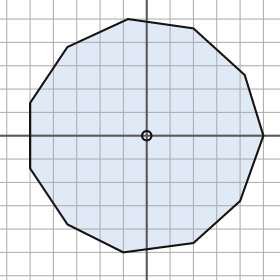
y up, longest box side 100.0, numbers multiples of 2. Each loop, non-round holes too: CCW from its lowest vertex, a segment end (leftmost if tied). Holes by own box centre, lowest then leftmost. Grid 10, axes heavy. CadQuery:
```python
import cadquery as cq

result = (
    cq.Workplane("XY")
    .moveTo(-10.0, -50.0)
    .lineTo(20.0, -46.0)
    .lineTo(40.0, -28.0)
    .lineTo(50.0, 0.0)
    .lineTo(42.0, 26.0)
    .lineTo(20.0, 46.0)
    .lineTo(-8.0, 50.0)
    .lineTo(-34.0, 38.0)
    .lineTo(-50.0, 14.0)
    .lineTo(-50.0, -14.0)
    .lineTo(-34.0, -38.0)
    .close()
    .moveTo(0.0, 0.0)
    .circle(2.0)
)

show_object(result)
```